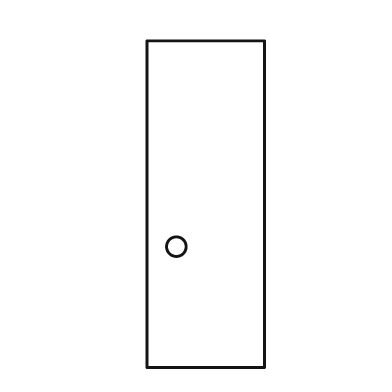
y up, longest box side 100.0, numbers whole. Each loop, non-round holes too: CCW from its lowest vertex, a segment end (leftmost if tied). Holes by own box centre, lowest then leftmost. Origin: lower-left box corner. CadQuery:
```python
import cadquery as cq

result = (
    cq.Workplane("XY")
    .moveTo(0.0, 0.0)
    .lineTo(36.0, 0.0)
    .lineTo(36.0, 100.0)
    .lineTo(0.0, 100.0)
    .close()
    .moveTo(9.0, 37.0)
    .circle(3.0)
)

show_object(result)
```